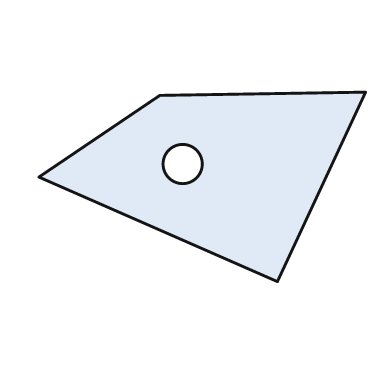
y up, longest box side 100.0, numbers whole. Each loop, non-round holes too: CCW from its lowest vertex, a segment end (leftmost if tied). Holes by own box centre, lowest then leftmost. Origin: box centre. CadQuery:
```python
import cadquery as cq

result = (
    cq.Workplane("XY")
    .moveTo(23.0, -29.0)
    .lineTo(50.0, 29.0)
    .lineTo(-13.0, 28.0)
    .lineTo(-50.0, 3.0)
    .close()
    .moveTo(-6.0, 7.0)
    .circle(6.0)
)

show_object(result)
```